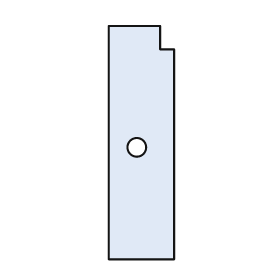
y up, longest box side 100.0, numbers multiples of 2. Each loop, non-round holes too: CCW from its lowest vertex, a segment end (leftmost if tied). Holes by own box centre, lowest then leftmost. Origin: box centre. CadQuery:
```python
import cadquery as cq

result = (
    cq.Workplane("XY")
    .moveTo(-14.0, -50.0)
    .lineTo(14.0, -50.0)
    .lineTo(14.0, 40.0)
    .lineTo(8.0, 40.0)
    .lineTo(8.0, 50.0)
    .lineTo(-14.0, 50.0)
    .close()
    .moveTo(-2.0, -2.0)
    .circle(4.0)
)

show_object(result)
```